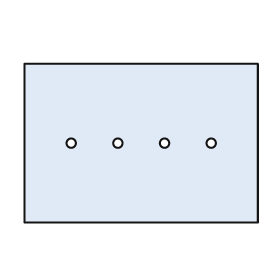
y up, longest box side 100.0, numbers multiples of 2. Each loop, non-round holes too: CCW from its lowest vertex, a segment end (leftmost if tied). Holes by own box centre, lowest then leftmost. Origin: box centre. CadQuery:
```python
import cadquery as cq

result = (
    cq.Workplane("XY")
    .moveTo(-50.0, -34.0)
    .lineTo(50.0, -34.0)
    .lineTo(50.0, 34.0)
    .lineTo(-50.0, 34.0)
    .close()
    .moveTo(-30.0, 0.0)
    .circle(2.0)
    .moveTo(-10.0, 0.0)
    .circle(2.0)
    .moveTo(10.0, 0.0)
    .circle(2.0)
    .moveTo(30.0, 0.0)
    .circle(2.0)
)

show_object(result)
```